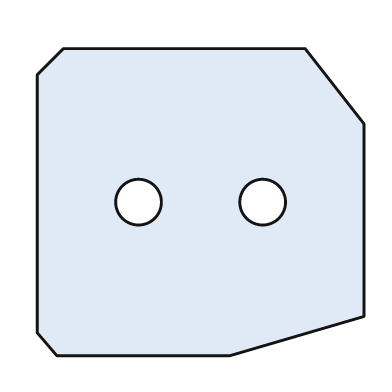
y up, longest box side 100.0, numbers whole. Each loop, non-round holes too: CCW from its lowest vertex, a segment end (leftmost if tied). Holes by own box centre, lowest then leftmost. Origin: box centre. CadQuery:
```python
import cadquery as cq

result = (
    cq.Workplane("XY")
    .moveTo(-44.0, -47.0)
    .lineTo(9.0, -47.0)
    .lineTo(50.0, -35.0)
    .lineTo(50.0, 24.0)
    .lineTo(32.0, 47.0)
    .lineTo(-42.0, 47.0)
    .lineTo(-50.0, 39.0)
    .lineTo(-50.0, -40.0)
    .close()
    .moveTo(-19.0, 0.0)
    .circle(7.0)
    .moveTo(19.0, 0.0)
    .circle(7.0)
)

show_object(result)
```